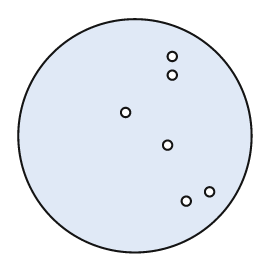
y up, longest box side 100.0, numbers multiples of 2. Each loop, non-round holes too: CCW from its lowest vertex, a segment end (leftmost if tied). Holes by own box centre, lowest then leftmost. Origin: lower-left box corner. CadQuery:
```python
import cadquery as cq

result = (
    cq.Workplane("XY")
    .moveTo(50.0, 50.0)
    .circle(50.0)
    .moveTo(72.0, 22.0)
    .circle(2.0)
    .moveTo(82.0, 26.0)
    .circle(2.0)
    .moveTo(64.0, 46.0)
    .circle(2.0)
    .moveTo(46.0, 60.0)
    .circle(2.0)
    .moveTo(66.0, 76.0)
    .circle(2.0)
    .moveTo(66.0, 84.0)
    .circle(2.0)
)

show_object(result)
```